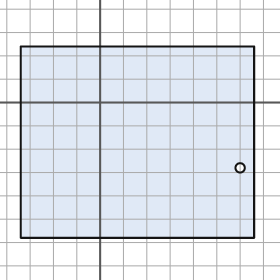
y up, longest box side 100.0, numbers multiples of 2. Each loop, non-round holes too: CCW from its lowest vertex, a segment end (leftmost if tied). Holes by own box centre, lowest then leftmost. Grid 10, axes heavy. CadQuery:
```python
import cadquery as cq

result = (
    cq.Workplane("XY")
    .moveTo(-34.0, -58.0)
    .lineTo(66.0, -58.0)
    .lineTo(66.0, 24.0)
    .lineTo(-34.0, 24.0)
    .close()
    .moveTo(60.0, -28.0)
    .circle(2.0)
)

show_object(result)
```